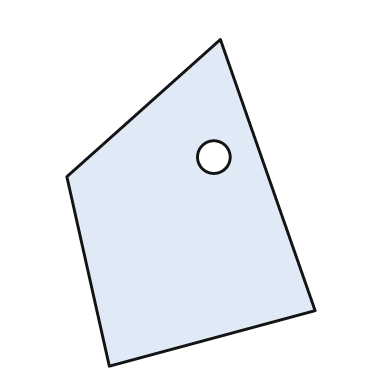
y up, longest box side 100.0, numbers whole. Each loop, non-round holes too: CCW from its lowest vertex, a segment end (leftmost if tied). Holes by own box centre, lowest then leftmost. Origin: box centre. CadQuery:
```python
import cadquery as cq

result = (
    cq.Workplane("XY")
    .moveTo(-25.0, -50.0)
    .lineTo(38.0, -33.0)
    .lineTo(9.0, 50.0)
    .lineTo(-38.0, 8.0)
    .close()
    .moveTo(7.0, 14.0)
    .circle(5.0)
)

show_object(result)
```